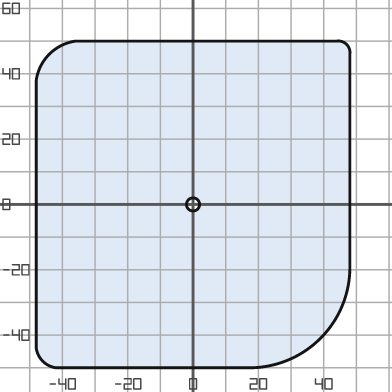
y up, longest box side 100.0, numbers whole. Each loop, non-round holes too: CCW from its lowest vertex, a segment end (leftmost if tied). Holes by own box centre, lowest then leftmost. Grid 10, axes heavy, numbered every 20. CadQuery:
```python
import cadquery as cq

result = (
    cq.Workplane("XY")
    .moveTo(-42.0, -50.0)
    .lineTo(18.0, -50.0)
    .threePointArc((39.0, -41.0), (48.0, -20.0))
    .lineTo(48.0, 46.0)
    .threePointArc((47.0, 49.0), (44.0, 50.0))
    .lineTo(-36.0, 50.0)
    .threePointArc((-44.0, 46.0), (-48.0, 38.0))
    .lineTo(-48.0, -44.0)
    .threePointArc((-46.0, -48.0), (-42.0, -50.0))
    .close()
    .moveTo(0.0, 0.0)
    .circle(2.0)
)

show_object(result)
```